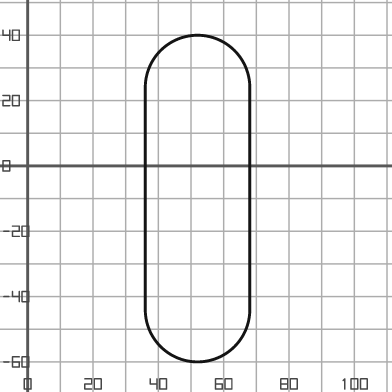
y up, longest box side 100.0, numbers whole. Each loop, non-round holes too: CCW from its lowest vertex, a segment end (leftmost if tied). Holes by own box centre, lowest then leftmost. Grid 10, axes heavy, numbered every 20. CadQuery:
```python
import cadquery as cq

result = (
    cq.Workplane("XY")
    .moveTo(36.0, -44.0)
    .threePointArc((52.0, -60.0), (68.0, -44.0))
    .lineTo(68.0, 24.0)
    .threePointArc((52.0, 40.0), (36.0, 24.0))
    .close()
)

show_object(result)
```